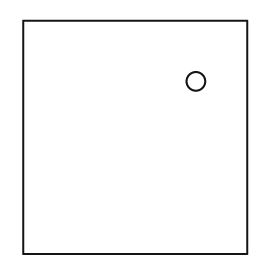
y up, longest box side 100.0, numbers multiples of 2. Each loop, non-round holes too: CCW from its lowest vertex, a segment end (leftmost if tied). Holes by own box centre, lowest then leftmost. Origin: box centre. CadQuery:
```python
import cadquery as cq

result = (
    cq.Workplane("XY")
    .moveTo(-48.0, -50.0)
    .lineTo(48.0, -50.0)
    .lineTo(48.0, 50.0)
    .lineTo(-48.0, 50.0)
    .close()
    .moveTo(26.0, 24.0)
    .circle(4.0)
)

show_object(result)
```